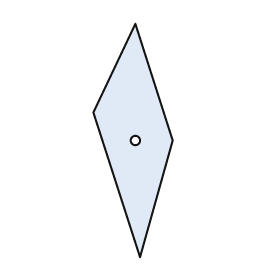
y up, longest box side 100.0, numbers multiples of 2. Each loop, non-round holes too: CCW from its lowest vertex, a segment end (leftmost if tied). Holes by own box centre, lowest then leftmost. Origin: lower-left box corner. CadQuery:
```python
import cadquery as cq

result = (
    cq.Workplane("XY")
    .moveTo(20.0, 0.0)
    .lineTo(34.0, 50.0)
    .lineTo(18.0, 100.0)
    .lineTo(0.0, 62.0)
    .close()
    .moveTo(18.0, 50.0)
    .circle(2.0)
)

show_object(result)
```